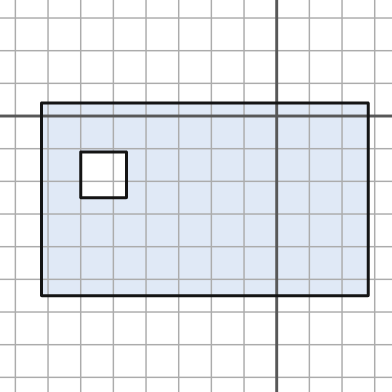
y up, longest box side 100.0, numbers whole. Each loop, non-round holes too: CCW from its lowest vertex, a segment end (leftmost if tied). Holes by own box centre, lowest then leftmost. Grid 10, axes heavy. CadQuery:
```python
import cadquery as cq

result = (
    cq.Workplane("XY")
    .moveTo(-72.0, -55.0)
    .lineTo(28.0, -55.0)
    .lineTo(28.0, 4.0)
    .lineTo(-72.0, 4.0)
    .close()
    .moveTo(-60.0, -25.0)
    .lineTo(-46.0, -25.0)
    .lineTo(-46.0, -11.0)
    .lineTo(-60.0, -11.0)
    .close()
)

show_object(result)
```